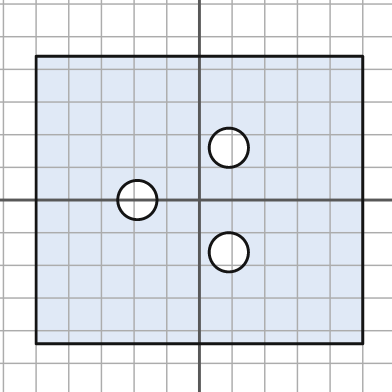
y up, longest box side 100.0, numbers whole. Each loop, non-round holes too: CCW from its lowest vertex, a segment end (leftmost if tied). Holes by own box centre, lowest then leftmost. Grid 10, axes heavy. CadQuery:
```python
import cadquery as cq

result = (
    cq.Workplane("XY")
    .moveTo(-50.0, -44.0)
    .lineTo(50.0, -44.0)
    .lineTo(50.0, 44.0)
    .lineTo(-50.0, 44.0)
    .close()
    .moveTo(9.0, -16.0)
    .circle(6.0)
    .moveTo(-19.0, 0.0)
    .circle(6.0)
    .moveTo(9.0, 16.0)
    .circle(6.0)
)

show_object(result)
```